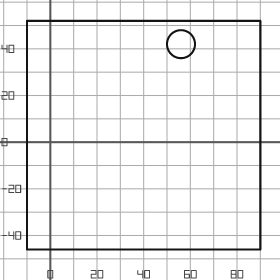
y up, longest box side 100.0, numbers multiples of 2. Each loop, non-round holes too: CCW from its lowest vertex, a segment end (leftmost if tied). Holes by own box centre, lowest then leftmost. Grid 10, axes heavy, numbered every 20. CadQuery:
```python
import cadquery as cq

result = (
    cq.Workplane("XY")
    .moveTo(-10.0, -46.0)
    .lineTo(90.0, -46.0)
    .lineTo(90.0, 52.0)
    .lineTo(-10.0, 52.0)
    .close()
    .moveTo(56.0, 42.0)
    .circle(6.0)
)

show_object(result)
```